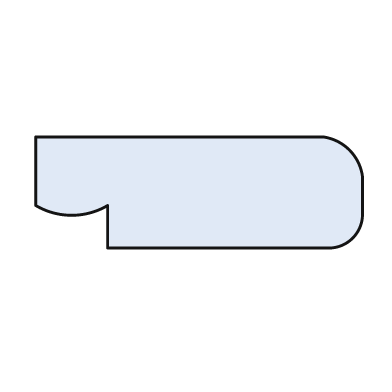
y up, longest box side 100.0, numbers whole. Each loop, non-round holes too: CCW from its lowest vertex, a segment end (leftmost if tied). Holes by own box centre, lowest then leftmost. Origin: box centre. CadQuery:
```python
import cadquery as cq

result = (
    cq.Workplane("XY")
    .moveTo(-28.0, -17.0)
    .lineTo(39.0, -17.0)
    .threePointArc((47.0, -14.0), (50.0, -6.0))
    .lineTo(50.0, 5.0)
    .threePointArc((46.0, 13.0), (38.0, 17.0))
    .lineTo(-50.0, 17.0)
    .lineTo(-50.0, -4.0)
    .threePointArc((-39.0, -7.0), (-28.0, -4.0))
    .close()
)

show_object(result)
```